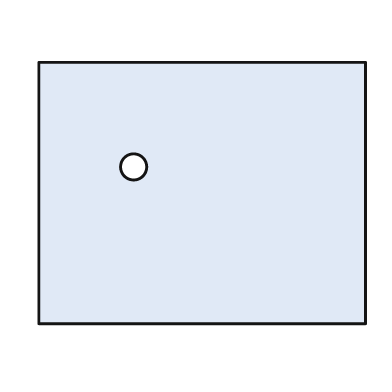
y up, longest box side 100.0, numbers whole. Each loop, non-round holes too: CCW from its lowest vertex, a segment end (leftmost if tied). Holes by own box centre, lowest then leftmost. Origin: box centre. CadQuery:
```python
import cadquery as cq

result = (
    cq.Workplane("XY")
    .moveTo(-50.0, -40.0)
    .lineTo(50.0, -40.0)
    .lineTo(50.0, 40.0)
    .lineTo(-50.0, 40.0)
    .close()
    .moveTo(-21.0, 8.0)
    .circle(4.0)
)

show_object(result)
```